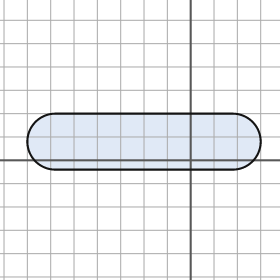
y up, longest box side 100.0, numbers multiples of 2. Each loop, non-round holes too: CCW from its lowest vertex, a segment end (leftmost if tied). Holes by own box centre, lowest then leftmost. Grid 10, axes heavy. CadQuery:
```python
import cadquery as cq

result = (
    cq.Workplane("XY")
    .moveTo(-58.0, -4.0)
    .lineTo(18.0, -4.0)
    .threePointArc((30.0, 8.0), (18.0, 20.0))
    .lineTo(-58.0, 20.0)
    .threePointArc((-70.0, 8.0), (-58.0, -4.0))
    .close()
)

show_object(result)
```